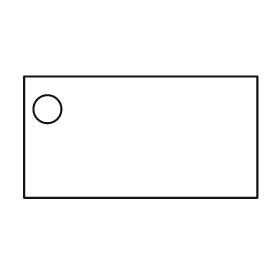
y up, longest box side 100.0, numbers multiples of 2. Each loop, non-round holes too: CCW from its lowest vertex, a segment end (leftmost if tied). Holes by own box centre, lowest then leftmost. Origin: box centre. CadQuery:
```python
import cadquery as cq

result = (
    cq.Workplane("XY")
    .moveTo(-50.0, -26.0)
    .lineTo(50.0, -26.0)
    .lineTo(50.0, 26.0)
    .lineTo(-50.0, 26.0)
    .close()
    .moveTo(-40.0, 12.0)
    .circle(6.0)
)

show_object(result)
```